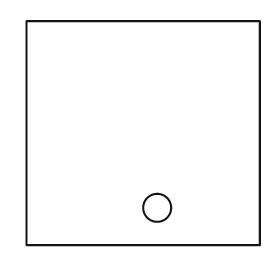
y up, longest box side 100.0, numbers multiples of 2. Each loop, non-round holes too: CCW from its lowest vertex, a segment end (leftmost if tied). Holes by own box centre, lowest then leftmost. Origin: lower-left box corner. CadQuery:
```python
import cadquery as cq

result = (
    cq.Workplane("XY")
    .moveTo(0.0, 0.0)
    .lineTo(100.0, 0.0)
    .lineTo(100.0, 96.0)
    .lineTo(0.0, 96.0)
    .close()
    .moveTo(56.0, 16.0)
    .circle(6.0)
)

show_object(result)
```